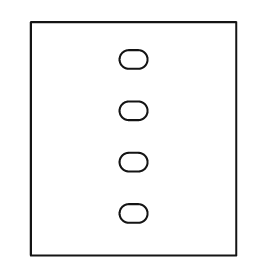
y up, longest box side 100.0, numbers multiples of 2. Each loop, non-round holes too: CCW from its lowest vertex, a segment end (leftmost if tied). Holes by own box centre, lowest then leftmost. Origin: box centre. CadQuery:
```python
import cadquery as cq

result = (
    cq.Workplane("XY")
    .moveTo(-44.0, -50.0)
    .lineTo(44.0, -50.0)
    .lineTo(44.0, 50.0)
    .lineTo(-44.0, 50.0)
    .close()
    .moveTo(-2.0, -36.0)
    .lineTo(2.0, -36.0)
    .threePointArc((6.0, -32.0), (2.0, -28.0))
    .lineTo(-2.0, -28.0)
    .threePointArc((-6.0, -32.0), (-2.0, -36.0))
    .close()
    .moveTo(-2.0, -14.0)
    .lineTo(2.0, -14.0)
    .threePointArc((6.0, -10.0), (2.0, -6.0))
    .lineTo(-2.0, -6.0)
    .threePointArc((-6.0, -10.0), (-2.0, -14.0))
    .close()
    .moveTo(-2.0, 8.0)
    .lineTo(2.0, 8.0)
    .threePointArc((6.0, 12.0), (2.0, 16.0))
    .lineTo(-2.0, 16.0)
    .threePointArc((-6.0, 12.0), (-2.0, 8.0))
    .close()
    .moveTo(-2.0, 30.0)
    .lineTo(2.0, 30.0)
    .threePointArc((6.0, 34.0), (2.0, 38.0))
    .lineTo(-2.0, 38.0)
    .threePointArc((-6.0, 34.0), (-2.0, 30.0))
    .close()
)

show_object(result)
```